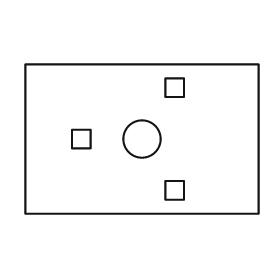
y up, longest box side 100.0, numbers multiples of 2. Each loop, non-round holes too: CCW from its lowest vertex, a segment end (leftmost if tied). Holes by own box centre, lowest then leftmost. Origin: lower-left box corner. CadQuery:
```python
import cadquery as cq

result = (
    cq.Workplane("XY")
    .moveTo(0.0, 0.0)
    .lineTo(100.0, 0.0)
    .lineTo(100.0, 64.0)
    .lineTo(0.0, 64.0)
    .close()
    .moveTo(60.0, 6.0)
    .lineTo(68.0, 6.0)
    .lineTo(68.0, 14.0)
    .lineTo(60.0, 14.0)
    .close()
    .moveTo(20.0, 28.0)
    .lineTo(28.0, 28.0)
    .lineTo(28.0, 36.0)
    .lineTo(20.0, 36.0)
    .close()
    .moveTo(50.0, 32.0)
    .circle(8.0)
    .moveTo(60.0, 50.0)
    .lineTo(68.0, 50.0)
    .lineTo(68.0, 58.0)
    .lineTo(60.0, 58.0)
    .close()
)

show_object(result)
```